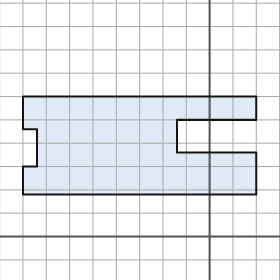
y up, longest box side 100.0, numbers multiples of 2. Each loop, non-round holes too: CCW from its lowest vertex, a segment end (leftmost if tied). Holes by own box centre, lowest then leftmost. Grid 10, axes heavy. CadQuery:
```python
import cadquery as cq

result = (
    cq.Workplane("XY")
    .moveTo(-80.0, 18.0)
    .lineTo(20.0, 18.0)
    .lineTo(20.0, 36.0)
    .lineTo(-14.0, 36.0)
    .lineTo(-14.0, 50.0)
    .lineTo(20.0, 50.0)
    .lineTo(20.0, 60.0)
    .lineTo(-80.0, 60.0)
    .lineTo(-80.0, 46.0)
    .lineTo(-74.0, 46.0)
    .lineTo(-74.0, 30.0)
    .lineTo(-80.0, 30.0)
    .close()
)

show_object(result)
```